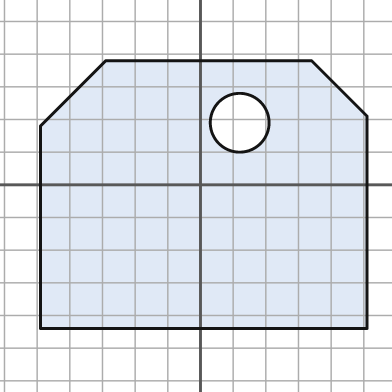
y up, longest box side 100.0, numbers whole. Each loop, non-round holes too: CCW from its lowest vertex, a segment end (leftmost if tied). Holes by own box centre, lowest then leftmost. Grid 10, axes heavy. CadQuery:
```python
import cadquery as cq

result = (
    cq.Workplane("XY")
    .moveTo(-49.0, -44.0)
    .lineTo(51.0, -44.0)
    .lineTo(51.0, 21.0)
    .lineTo(34.0, 38.0)
    .lineTo(-29.0, 38.0)
    .lineTo(-49.0, 18.0)
    .close()
    .moveTo(12.0, 19.0)
    .circle(9.0)
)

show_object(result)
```